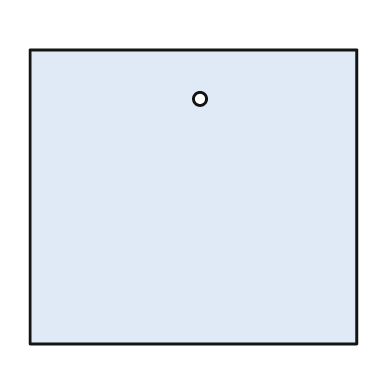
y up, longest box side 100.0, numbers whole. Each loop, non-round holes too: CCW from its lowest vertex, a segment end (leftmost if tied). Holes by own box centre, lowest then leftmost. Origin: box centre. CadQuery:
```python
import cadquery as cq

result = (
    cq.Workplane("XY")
    .moveTo(-50.0, -45.0)
    .lineTo(50.0, -45.0)
    .lineTo(50.0, 45.0)
    .lineTo(-50.0, 45.0)
    .close()
    .moveTo(2.0, 30.0)
    .circle(2.0)
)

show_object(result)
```